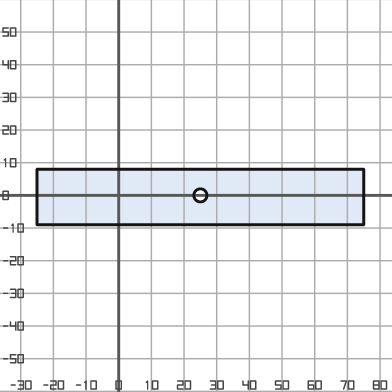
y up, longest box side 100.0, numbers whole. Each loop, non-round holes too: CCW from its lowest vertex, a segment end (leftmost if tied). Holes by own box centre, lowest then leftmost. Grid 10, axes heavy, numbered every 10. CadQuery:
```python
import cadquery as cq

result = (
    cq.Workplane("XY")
    .moveTo(-25.0, -9.0)
    .lineTo(75.0, -9.0)
    .lineTo(75.0, 8.0)
    .lineTo(-25.0, 8.0)
    .close()
    .moveTo(25.0, 0.0)
    .circle(2.0)
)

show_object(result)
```